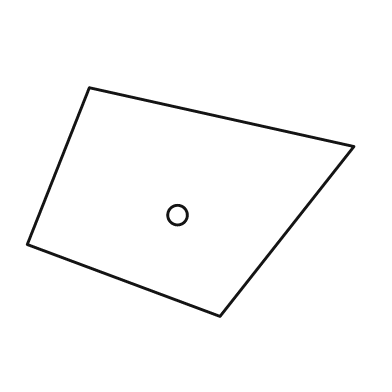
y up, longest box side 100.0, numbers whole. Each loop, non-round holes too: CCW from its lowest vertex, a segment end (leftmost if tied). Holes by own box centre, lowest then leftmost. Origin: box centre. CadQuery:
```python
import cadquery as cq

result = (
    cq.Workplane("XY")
    .moveTo(9.0, -35.0)
    .lineTo(50.0, 17.0)
    .lineTo(-31.0, 35.0)
    .lineTo(-50.0, -13.0)
    .close()
    .moveTo(-4.0, -4.0)
    .circle(3.0)
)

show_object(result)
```